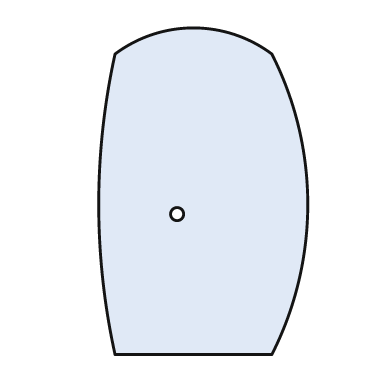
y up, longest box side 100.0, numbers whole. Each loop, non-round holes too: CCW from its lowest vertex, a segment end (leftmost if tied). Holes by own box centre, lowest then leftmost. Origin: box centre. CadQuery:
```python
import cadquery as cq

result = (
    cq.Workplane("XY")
    .moveTo(-27.0, -50.0)
    .lineTo(21.0, -50.0)
    .threePointArc((32.0, -4.0), (21.0, 42.0))
    .threePointArc((-3.0, 50.0), (-27.0, 42.0))
    .threePointArc((-32.0, -4.0), (-27.0, -50.0))
    .close()
    .moveTo(-8.0, -7.0)
    .circle(2.0)
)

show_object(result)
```